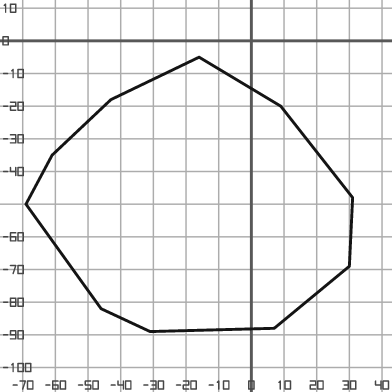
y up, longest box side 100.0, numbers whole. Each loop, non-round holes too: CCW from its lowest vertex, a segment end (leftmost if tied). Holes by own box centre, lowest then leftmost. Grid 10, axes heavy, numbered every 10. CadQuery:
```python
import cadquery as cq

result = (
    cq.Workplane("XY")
    .moveTo(-31.0, -89.0)
    .lineTo(7.0, -88.0)
    .lineTo(30.0, -69.0)
    .lineTo(31.0, -48.0)
    .lineTo(9.0, -20.0)
    .lineTo(-16.0, -5.0)
    .lineTo(-43.0, -18.0)
    .lineTo(-61.0, -35.0)
    .lineTo(-69.0, -50.0)
    .lineTo(-46.0, -82.0)
    .close()
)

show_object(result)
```